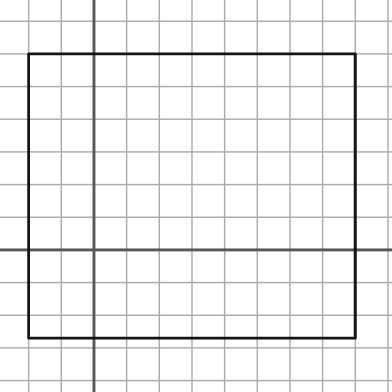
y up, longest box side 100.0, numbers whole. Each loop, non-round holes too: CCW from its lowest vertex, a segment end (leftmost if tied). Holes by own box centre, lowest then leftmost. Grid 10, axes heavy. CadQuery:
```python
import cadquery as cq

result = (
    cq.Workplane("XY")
    .moveTo(-20.0, -27.0)
    .lineTo(80.0, -27.0)
    .lineTo(80.0, 60.0)
    .lineTo(-20.0, 60.0)
    .close()
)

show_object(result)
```